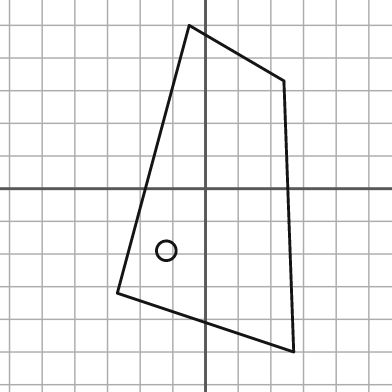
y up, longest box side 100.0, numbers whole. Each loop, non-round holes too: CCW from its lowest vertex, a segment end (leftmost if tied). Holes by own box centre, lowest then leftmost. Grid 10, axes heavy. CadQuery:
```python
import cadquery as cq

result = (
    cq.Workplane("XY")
    .moveTo(27.0, -50.0)
    .lineTo(24.0, 33.0)
    .lineTo(-5.0, 50.0)
    .lineTo(-27.0, -32.0)
    .close()
    .moveTo(-12.0, -19.0)
    .circle(3.0)
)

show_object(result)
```